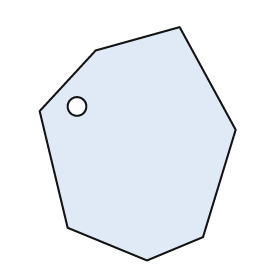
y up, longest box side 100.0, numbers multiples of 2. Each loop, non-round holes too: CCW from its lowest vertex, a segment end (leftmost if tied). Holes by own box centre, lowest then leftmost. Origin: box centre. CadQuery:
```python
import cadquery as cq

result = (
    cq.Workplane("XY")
    .moveTo(4.0, -50.0)
    .lineTo(28.0, -40.0)
    .lineTo(42.0, 6.0)
    .lineTo(18.0, 50.0)
    .lineTo(-18.0, 40.0)
    .lineTo(-42.0, 14.0)
    .lineTo(-30.0, -36.0)
    .close()
    .moveTo(-26.0, 16.0)
    .circle(4.0)
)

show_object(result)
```